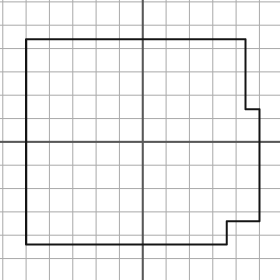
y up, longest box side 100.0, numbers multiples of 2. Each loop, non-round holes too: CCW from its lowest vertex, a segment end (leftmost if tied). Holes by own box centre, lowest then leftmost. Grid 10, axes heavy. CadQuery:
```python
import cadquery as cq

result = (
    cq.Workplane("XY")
    .moveTo(-50.0, -44.0)
    .lineTo(36.0, -44.0)
    .lineTo(36.0, -34.0)
    .lineTo(50.0, -34.0)
    .lineTo(50.0, 14.0)
    .lineTo(44.0, 14.0)
    .lineTo(44.0, 44.0)
    .lineTo(-50.0, 44.0)
    .close()
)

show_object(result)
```